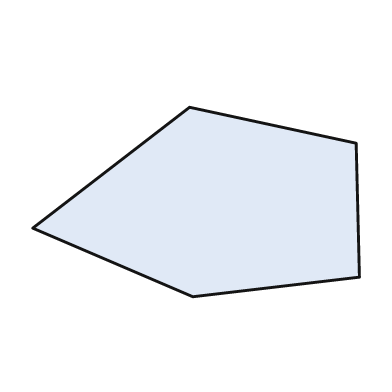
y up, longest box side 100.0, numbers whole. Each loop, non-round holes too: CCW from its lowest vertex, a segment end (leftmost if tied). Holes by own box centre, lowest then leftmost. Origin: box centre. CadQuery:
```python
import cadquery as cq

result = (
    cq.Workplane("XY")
    .moveTo(-1.0, -29.0)
    .lineTo(50.0, -23.0)
    .lineTo(49.0, 18.0)
    .lineTo(-2.0, 29.0)
    .lineTo(-50.0, -8.0)
    .close()
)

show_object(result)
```